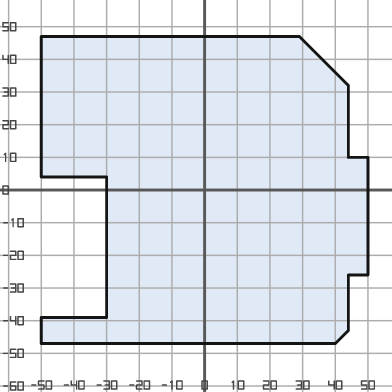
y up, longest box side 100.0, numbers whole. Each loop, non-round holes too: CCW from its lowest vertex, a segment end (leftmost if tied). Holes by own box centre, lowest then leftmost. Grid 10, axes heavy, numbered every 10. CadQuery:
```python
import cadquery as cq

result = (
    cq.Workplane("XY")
    .moveTo(-50.0, -47.0)
    .lineTo(40.0, -47.0)
    .lineTo(44.0, -43.0)
    .lineTo(44.0, -26.0)
    .lineTo(50.0, -26.0)
    .lineTo(50.0, 10.0)
    .lineTo(44.0, 10.0)
    .lineTo(44.0, 32.0)
    .lineTo(29.0, 47.0)
    .lineTo(-50.0, 47.0)
    .lineTo(-50.0, 4.0)
    .lineTo(-30.0, 4.0)
    .lineTo(-30.0, -39.0)
    .lineTo(-50.0, -39.0)
    .close()
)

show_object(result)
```